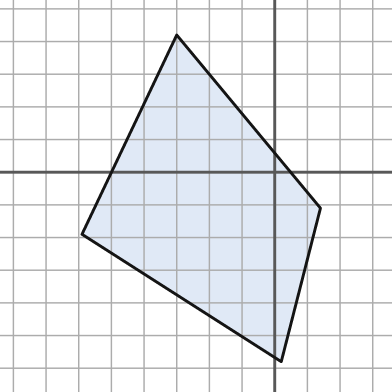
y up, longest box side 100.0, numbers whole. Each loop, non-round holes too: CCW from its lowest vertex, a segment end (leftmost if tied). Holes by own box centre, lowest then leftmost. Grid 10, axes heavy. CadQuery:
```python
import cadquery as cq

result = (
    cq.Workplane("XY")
    .moveTo(2.0, -58.0)
    .lineTo(14.0, -11.0)
    .lineTo(-30.0, 42.0)
    .lineTo(-59.0, -19.0)
    .close()
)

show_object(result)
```